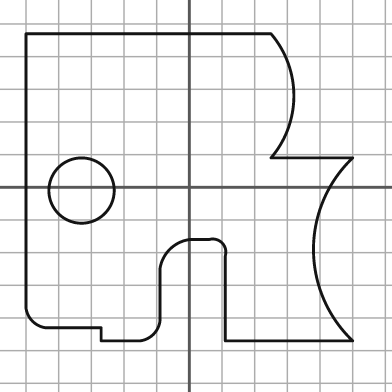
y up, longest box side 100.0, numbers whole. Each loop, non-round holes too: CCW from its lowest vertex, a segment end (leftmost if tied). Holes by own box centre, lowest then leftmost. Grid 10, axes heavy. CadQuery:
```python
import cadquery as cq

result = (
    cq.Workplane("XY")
    .moveTo(-27.0, -47.0)
    .lineTo(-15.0, -47.0)
    .threePointArc((-11.0, -45.0), (-9.0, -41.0))
    .lineTo(-9.0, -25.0)
    .threePointArc((-6.0, -19.0), (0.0, -16.0))
    .lineTo(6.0, -16.0)
    .threePointArc((10.0, -17.0), (11.0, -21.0))
    .lineTo(11.0, -47.0)
    .lineTo(50.0, -47.0)
    .threePointArc((38.0, -19.0), (50.0, 9.0))
    .lineTo(25.0, 9.0)
    .threePointArc((32.0, 28.0), (25.0, 47.0))
    .lineTo(-50.0, 47.0)
    .lineTo(-50.0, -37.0)
    .threePointArc((-48.0, -41.0), (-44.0, -43.0))
    .lineTo(-27.0, -43.0)
    .close()
    .moveTo(-33.0, -1.0)
    .circle(10.0)
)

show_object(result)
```